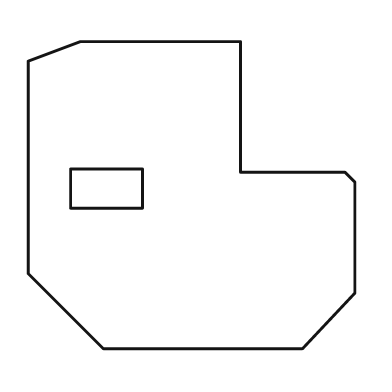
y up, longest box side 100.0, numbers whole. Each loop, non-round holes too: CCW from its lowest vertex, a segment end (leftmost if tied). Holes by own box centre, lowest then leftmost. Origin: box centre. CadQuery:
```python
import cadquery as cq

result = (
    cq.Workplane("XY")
    .moveTo(-27.0, -47.0)
    .lineTo(34.0, -47.0)
    .lineTo(50.0, -30.0)
    .lineTo(50.0, 4.0)
    .lineTo(47.0, 7.0)
    .lineTo(15.0, 7.0)
    .lineTo(15.0, 47.0)
    .lineTo(-34.0, 47.0)
    .lineTo(-50.0, 41.0)
    .lineTo(-50.0, -24.0)
    .close()
    .moveTo(-37.0, -4.0)
    .lineTo(-15.0, -4.0)
    .lineTo(-15.0, 8.0)
    .lineTo(-37.0, 8.0)
    .close()
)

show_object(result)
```